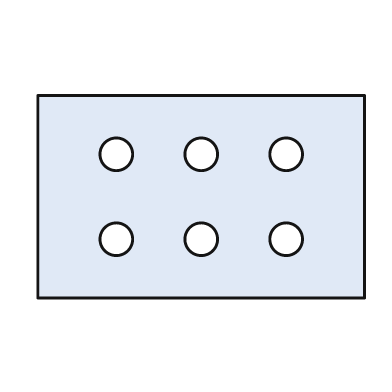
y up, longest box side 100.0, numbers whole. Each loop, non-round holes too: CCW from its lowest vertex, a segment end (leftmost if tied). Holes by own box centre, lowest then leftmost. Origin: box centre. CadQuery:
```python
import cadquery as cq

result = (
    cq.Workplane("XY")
    .moveTo(-50.0, -31.0)
    .lineTo(50.0, -31.0)
    .lineTo(50.0, 31.0)
    .lineTo(-50.0, 31.0)
    .close()
    .moveTo(-26.0, -13.0)
    .circle(5.0)
    .moveTo(0.0, -13.0)
    .circle(5.0)
    .moveTo(26.0, -13.0)
    .circle(5.0)
    .moveTo(-26.0, 13.0)
    .circle(5.0)
    .moveTo(0.0, 13.0)
    .circle(5.0)
    .moveTo(26.0, 13.0)
    .circle(5.0)
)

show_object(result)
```